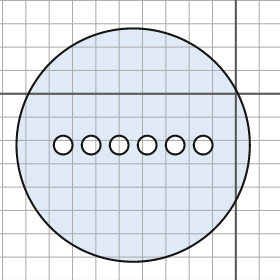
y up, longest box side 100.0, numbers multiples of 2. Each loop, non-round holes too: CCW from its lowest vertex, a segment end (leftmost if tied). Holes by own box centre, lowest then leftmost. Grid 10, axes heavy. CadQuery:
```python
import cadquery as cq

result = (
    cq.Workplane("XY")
    .moveTo(-44.0, -22.0)
    .circle(50.0)
    .moveTo(-74.0, -22.0)
    .circle(4.0)
    .moveTo(-62.0, -22.0)
    .circle(4.0)
    .moveTo(-50.0, -22.0)
    .circle(4.0)
    .moveTo(-38.0, -22.0)
    .circle(4.0)
    .moveTo(-26.0, -22.0)
    .circle(4.0)
    .moveTo(-14.0, -22.0)
    .circle(4.0)
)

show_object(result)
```